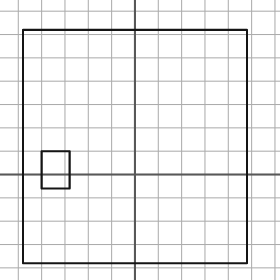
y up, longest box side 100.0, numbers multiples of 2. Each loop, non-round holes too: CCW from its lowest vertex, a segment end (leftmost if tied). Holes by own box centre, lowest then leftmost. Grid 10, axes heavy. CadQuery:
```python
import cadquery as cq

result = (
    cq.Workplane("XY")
    .moveTo(-48.0, -38.0)
    .lineTo(48.0, -38.0)
    .lineTo(48.0, 62.0)
    .lineTo(-48.0, 62.0)
    .close()
    .moveTo(-40.0, -6.0)
    .lineTo(-28.0, -6.0)
    .lineTo(-28.0, 10.0)
    .lineTo(-40.0, 10.0)
    .close()
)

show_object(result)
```